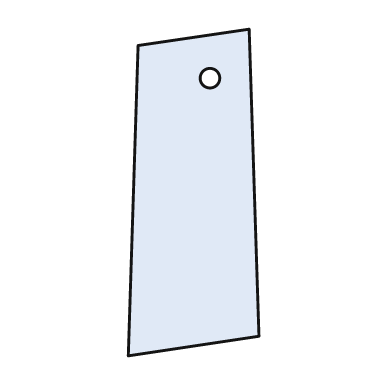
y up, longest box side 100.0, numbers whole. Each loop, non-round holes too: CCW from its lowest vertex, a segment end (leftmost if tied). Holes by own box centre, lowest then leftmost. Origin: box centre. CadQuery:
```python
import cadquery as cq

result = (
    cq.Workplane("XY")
    .moveTo(-20.0, -50.0)
    .lineTo(20.0, -44.0)
    .lineTo(17.0, 50.0)
    .lineTo(-17.0, 45.0)
    .close()
    .moveTo(5.0, 35.0)
    .circle(3.0)
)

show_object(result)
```